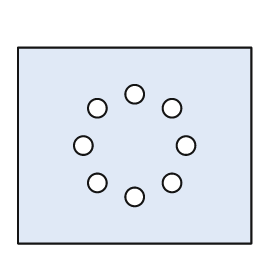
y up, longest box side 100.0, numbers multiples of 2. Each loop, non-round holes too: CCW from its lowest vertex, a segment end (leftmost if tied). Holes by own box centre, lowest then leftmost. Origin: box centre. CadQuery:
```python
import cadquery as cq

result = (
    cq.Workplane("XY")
    .moveTo(-50.0, -42.0)
    .lineTo(50.0, -42.0)
    .lineTo(50.0, 42.0)
    .lineTo(-50.0, 42.0)
    .close()
    .moveTo(0.0, -22.0)
    .circle(4.0)
    .moveTo(-16.0, -16.0)
    .circle(4.0)
    .moveTo(16.0, -16.0)
    .circle(4.0)
    .moveTo(-22.0, 0.0)
    .circle(4.0)
    .moveTo(22.0, 0.0)
    .circle(4.0)
    .moveTo(-16.0, 16.0)
    .circle(4.0)
    .moveTo(16.0, 16.0)
    .circle(4.0)
    .moveTo(0.0, 22.0)
    .circle(4.0)
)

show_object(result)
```